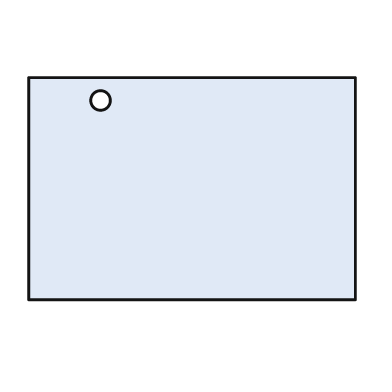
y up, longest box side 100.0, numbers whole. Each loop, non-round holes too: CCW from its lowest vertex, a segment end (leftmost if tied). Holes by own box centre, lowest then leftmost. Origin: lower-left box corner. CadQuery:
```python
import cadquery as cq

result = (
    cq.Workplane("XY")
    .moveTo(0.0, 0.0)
    .lineTo(100.0, 0.0)
    .lineTo(100.0, 68.0)
    .lineTo(0.0, 68.0)
    .close()
    .moveTo(22.0, 61.0)
    .circle(3.0)
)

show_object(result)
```